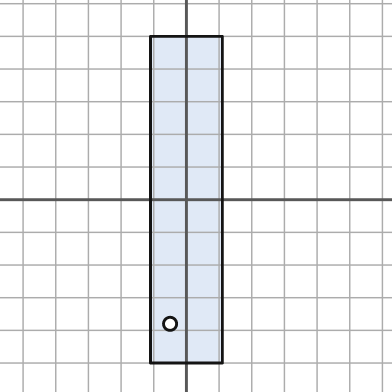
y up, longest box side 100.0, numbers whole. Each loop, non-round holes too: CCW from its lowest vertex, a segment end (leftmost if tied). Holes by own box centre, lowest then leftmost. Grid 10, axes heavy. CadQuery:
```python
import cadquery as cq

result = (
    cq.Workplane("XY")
    .moveTo(-11.0, -50.0)
    .lineTo(11.0, -50.0)
    .lineTo(11.0, 50.0)
    .lineTo(-11.0, 50.0)
    .close()
    .moveTo(-5.0, -38.0)
    .circle(2.0)
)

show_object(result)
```